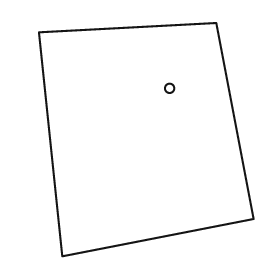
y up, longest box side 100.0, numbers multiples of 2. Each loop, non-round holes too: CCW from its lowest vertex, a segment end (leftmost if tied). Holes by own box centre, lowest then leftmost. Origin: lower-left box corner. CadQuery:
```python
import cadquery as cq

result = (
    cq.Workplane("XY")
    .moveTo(10.0, 0.0)
    .lineTo(92.0, 16.0)
    .lineTo(76.0, 100.0)
    .lineTo(0.0, 96.0)
    .close()
    .moveTo(56.0, 72.0)
    .circle(2.0)
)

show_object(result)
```